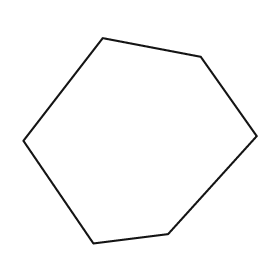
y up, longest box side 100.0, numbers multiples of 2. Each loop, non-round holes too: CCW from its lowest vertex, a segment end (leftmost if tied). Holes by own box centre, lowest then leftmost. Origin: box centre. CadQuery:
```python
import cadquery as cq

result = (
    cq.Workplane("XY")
    .moveTo(-20.0, -44.0)
    .lineTo(12.0, -40.0)
    .lineTo(50.0, 2.0)
    .lineTo(26.0, 36.0)
    .lineTo(-16.0, 44.0)
    .lineTo(-50.0, 0.0)
    .close()
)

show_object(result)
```